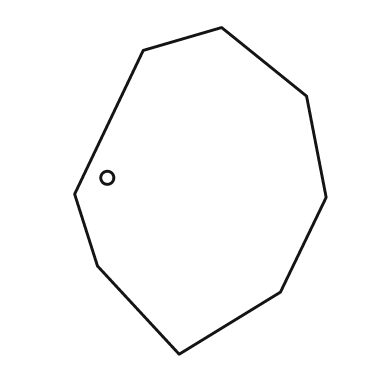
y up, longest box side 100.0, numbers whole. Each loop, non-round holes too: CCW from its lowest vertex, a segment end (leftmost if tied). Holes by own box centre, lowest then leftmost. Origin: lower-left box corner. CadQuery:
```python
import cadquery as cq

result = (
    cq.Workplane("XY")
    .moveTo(32.0, 0.0)
    .lineTo(63.0, 19.0)
    .lineTo(77.0, 48.0)
    .lineTo(71.0, 79.0)
    .lineTo(45.0, 100.0)
    .lineTo(21.0, 93.0)
    .lineTo(0.0, 49.0)
    .lineTo(7.0, 27.0)
    .close()
    .moveTo(10.0, 54.0)
    .circle(2.0)
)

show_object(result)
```